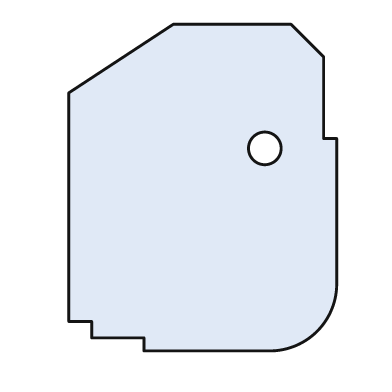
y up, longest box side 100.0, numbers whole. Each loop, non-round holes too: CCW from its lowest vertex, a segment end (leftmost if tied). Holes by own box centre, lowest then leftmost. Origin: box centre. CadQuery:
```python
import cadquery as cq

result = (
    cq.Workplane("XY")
    .moveTo(-18.0, -50.0)
    .lineTo(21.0, -50.0)
    .threePointArc((35.0, -44.0), (41.0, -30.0))
    .lineTo(41.0, 15.0)
    .lineTo(37.0, 15.0)
    .lineTo(37.0, 40.0)
    .lineTo(27.0, 50.0)
    .lineTo(-9.0, 50.0)
    .lineTo(-41.0, 29.0)
    .lineTo(-41.0, -41.0)
    .lineTo(-34.0, -41.0)
    .lineTo(-34.0, -46.0)
    .lineTo(-18.0, -46.0)
    .close()
    .moveTo(19.0, 12.0)
    .circle(5.0)
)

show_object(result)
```